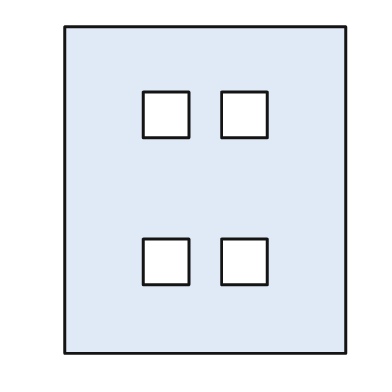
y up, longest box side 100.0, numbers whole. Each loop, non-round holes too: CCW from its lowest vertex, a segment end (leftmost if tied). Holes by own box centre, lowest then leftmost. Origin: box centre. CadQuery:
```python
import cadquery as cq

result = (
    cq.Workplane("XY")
    .moveTo(-43.0, -50.0)
    .lineTo(43.0, -50.0)
    .lineTo(43.0, 50.0)
    .lineTo(-43.0, 50.0)
    .close()
    .moveTo(-19.0, -29.0)
    .lineTo(-5.0, -29.0)
    .lineTo(-5.0, -15.0)
    .lineTo(-19.0, -15.0)
    .close()
    .moveTo(5.0, -29.0)
    .lineTo(19.0, -29.0)
    .lineTo(19.0, -15.0)
    .lineTo(5.0, -15.0)
    .close()
    .moveTo(-19.0, 16.0)
    .lineTo(-5.0, 16.0)
    .lineTo(-5.0, 30.0)
    .lineTo(-19.0, 30.0)
    .close()
    .moveTo(5.0, 16.0)
    .lineTo(19.0, 16.0)
    .lineTo(19.0, 30.0)
    .lineTo(5.0, 30.0)
    .close()
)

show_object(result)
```